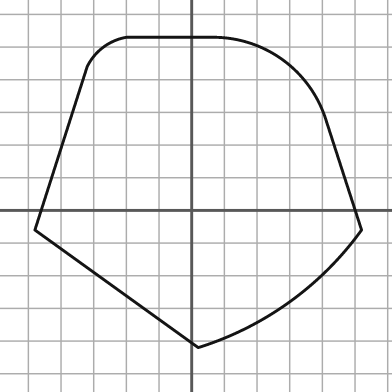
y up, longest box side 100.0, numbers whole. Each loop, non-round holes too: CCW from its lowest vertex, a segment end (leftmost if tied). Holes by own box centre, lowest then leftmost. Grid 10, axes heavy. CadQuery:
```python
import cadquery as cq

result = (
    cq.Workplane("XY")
    .moveTo(2.0, -42.0)
    .threePointArc((30.0, -28.0), (52.0, -6.0))
    .lineTo(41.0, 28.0)
    .threePointArc((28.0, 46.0), (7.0, 53.0))
    .lineTo(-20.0, 53.0)
    .threePointArc((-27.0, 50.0), (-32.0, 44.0))
    .lineTo(-48.0, -6.0)
    .close()
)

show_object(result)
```